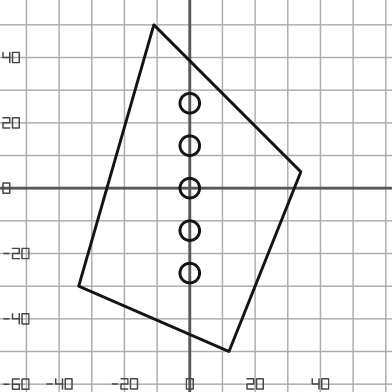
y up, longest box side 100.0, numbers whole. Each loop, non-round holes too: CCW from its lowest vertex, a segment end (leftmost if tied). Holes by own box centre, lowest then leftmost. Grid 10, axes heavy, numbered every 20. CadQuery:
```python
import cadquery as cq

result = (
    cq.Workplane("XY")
    .moveTo(12.0, -50.0)
    .lineTo(34.0, 5.0)
    .lineTo(-11.0, 50.0)
    .lineTo(-34.0, -30.0)
    .close()
    .moveTo(0.0, -26.0)
    .circle(3.0)
    .moveTo(0.0, -13.0)
    .circle(3.0)
    .moveTo(0.0, 0.0)
    .circle(3.0)
    .moveTo(0.0, 13.0)
    .circle(3.0)
    .moveTo(0.0, 26.0)
    .circle(3.0)
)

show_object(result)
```